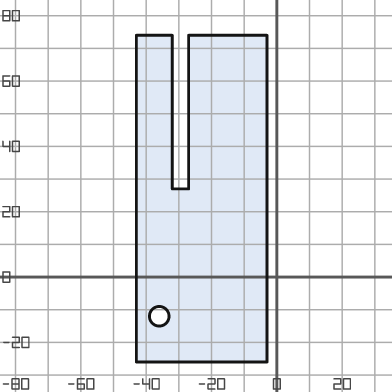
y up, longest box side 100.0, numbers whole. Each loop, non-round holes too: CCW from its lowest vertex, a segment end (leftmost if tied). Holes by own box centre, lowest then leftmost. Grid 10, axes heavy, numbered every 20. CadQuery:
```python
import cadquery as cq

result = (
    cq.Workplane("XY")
    .moveTo(-43.0, -26.0)
    .lineTo(-3.0, -26.0)
    .lineTo(-3.0, 74.0)
    .lineTo(-27.0, 74.0)
    .lineTo(-27.0, 27.0)
    .lineTo(-32.0, 27.0)
    .lineTo(-32.0, 74.0)
    .lineTo(-43.0, 74.0)
    .close()
    .moveTo(-36.0, -12.0)
    .circle(3.0)
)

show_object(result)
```